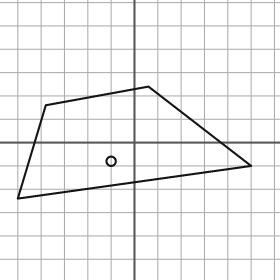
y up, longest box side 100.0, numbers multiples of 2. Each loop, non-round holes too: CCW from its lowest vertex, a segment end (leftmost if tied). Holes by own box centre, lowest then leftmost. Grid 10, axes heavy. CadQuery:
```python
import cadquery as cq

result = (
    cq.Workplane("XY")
    .moveTo(-50.0, -24.0)
    .lineTo(50.0, -10.0)
    .lineTo(6.0, 24.0)
    .lineTo(-38.0, 16.0)
    .close()
    .moveTo(-10.0, -8.0)
    .circle(2.0)
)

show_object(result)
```